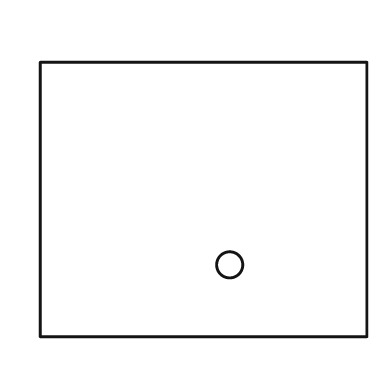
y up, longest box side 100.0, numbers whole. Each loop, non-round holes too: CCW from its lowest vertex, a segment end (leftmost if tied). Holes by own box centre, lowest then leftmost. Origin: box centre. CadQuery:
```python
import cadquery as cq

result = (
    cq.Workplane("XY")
    .moveTo(-50.0, -42.0)
    .lineTo(50.0, -42.0)
    .lineTo(50.0, 42.0)
    .lineTo(-50.0, 42.0)
    .close()
    .moveTo(8.0, -20.0)
    .circle(4.0)
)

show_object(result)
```